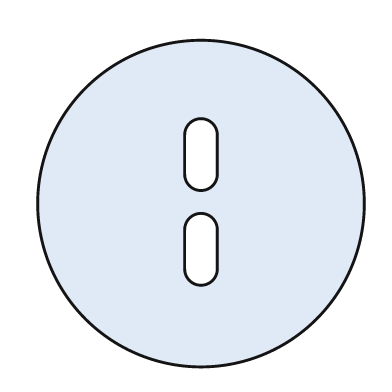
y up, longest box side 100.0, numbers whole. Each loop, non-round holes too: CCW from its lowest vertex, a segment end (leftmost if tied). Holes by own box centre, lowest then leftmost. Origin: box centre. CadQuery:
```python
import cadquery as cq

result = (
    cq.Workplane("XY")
    .moveTo(0.0, 0.0)
    .circle(50.0)
    .moveTo(-5.0, -20.0)
    .threePointArc((0.0, -25.0), (5.0, -20.0))
    .lineTo(5.0, -8.0)
    .threePointArc((0.0, -3.0), (-5.0, -8.0))
    .close()
    .moveTo(-5.0, 9.0)
    .threePointArc((0.0, 4.0), (5.0, 9.0))
    .lineTo(5.0, 21.0)
    .threePointArc((0.0, 26.0), (-5.0, 21.0))
    .close()
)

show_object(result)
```